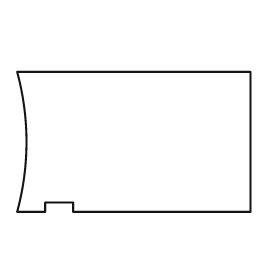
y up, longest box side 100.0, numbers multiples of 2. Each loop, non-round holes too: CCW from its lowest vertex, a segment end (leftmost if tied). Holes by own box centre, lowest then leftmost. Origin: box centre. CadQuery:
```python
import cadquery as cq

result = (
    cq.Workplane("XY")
    .moveTo(-50.0, -30.0)
    .lineTo(-38.0, -30.0)
    .lineTo(-38.0, -26.0)
    .lineTo(-26.0, -26.0)
    .lineTo(-26.0, -30.0)
    .lineTo(50.0, -30.0)
    .lineTo(50.0, 30.0)
    .lineTo(-50.0, 30.0)
    .threePointArc((-46.0, 0.0), (-50.0, -30.0))
    .close()
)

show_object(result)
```